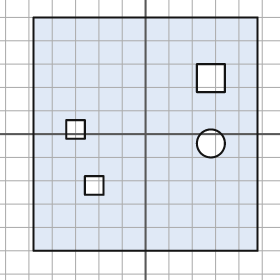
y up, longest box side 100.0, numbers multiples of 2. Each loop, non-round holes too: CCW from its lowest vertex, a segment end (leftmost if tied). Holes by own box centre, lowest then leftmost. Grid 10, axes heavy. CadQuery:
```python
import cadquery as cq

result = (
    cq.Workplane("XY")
    .moveTo(-48.0, -50.0)
    .lineTo(48.0, -50.0)
    .lineTo(48.0, 50.0)
    .lineTo(-48.0, 50.0)
    .close()
    .moveTo(-26.0, -26.0)
    .lineTo(-18.0, -26.0)
    .lineTo(-18.0, -18.0)
    .lineTo(-26.0, -18.0)
    .close()
    .moveTo(28.0, -4.0)
    .circle(6.0)
    .moveTo(-34.0, -2.0)
    .lineTo(-26.0, -2.0)
    .lineTo(-26.0, 6.0)
    .lineTo(-34.0, 6.0)
    .close()
    .moveTo(22.0, 18.0)
    .lineTo(34.0, 18.0)
    .lineTo(34.0, 30.0)
    .lineTo(22.0, 30.0)
    .close()
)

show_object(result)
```